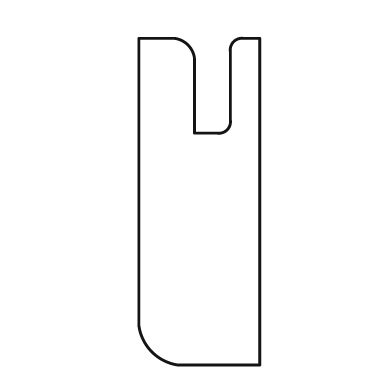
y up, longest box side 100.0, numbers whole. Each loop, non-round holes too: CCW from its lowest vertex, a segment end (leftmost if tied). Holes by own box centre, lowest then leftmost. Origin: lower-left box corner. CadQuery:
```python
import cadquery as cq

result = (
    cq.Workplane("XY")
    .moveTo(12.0, 0.0)
    .lineTo(37.0, 0.0)
    .lineTo(37.0, 100.0)
    .lineTo(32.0, 100.0)
    .threePointArc((29.0, 99.0), (28.0, 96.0))
    .lineTo(28.0, 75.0)
    .threePointArc((27.0, 72.0), (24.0, 71.0))
    .lineTo(17.0, 71.0)
    .lineTo(17.0, 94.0)
    .threePointArc((15.0, 98.0), (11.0, 100.0))
    .lineTo(0.0, 100.0)
    .lineTo(0.0, 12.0)
    .threePointArc((4.0, 4.0), (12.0, 0.0))
    .close()
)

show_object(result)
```